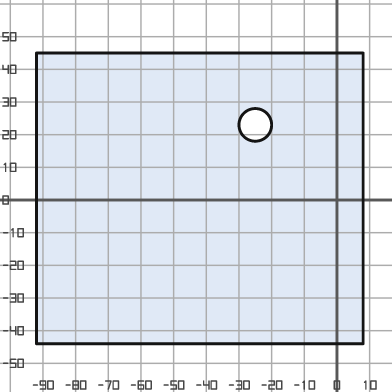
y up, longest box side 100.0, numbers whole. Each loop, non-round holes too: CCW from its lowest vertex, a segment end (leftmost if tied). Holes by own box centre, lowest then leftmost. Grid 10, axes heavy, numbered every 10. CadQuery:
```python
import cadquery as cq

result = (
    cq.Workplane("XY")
    .moveTo(-92.0, -44.0)
    .lineTo(8.0, -44.0)
    .lineTo(8.0, 45.0)
    .lineTo(-92.0, 45.0)
    .close()
    .moveTo(-25.0, 23.0)
    .circle(5.0)
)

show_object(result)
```